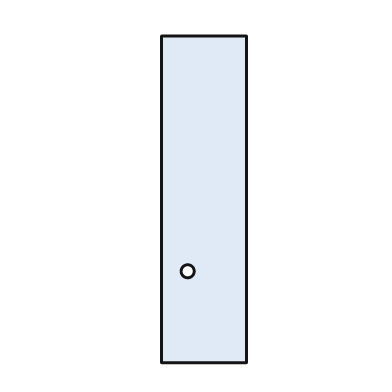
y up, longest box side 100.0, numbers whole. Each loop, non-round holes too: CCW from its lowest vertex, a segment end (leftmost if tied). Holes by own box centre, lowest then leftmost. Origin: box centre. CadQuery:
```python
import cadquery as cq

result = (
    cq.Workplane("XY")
    .moveTo(-13.0, -50.0)
    .lineTo(13.0, -50.0)
    .lineTo(13.0, 50.0)
    .lineTo(-13.0, 50.0)
    .close()
    .moveTo(-5.0, -22.0)
    .circle(2.0)
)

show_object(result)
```